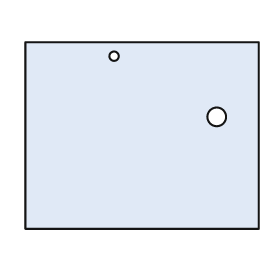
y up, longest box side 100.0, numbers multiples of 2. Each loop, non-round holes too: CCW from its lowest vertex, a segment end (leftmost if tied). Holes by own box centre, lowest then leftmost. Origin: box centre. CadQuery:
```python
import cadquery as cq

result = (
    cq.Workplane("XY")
    .moveTo(-50.0, -40.0)
    .lineTo(50.0, -40.0)
    .lineTo(50.0, 40.0)
    .lineTo(-50.0, 40.0)
    .close()
    .moveTo(32.0, 8.0)
    .circle(4.0)
    .moveTo(-12.0, 34.0)
    .circle(2.0)
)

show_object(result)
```